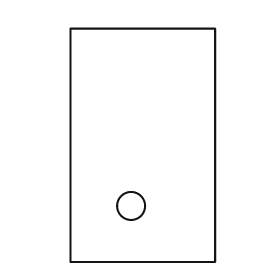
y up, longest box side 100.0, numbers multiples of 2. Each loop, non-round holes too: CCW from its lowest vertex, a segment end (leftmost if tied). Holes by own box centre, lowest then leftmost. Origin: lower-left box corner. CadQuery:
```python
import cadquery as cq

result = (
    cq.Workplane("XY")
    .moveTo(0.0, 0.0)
    .lineTo(62.0, 0.0)
    .lineTo(62.0, 100.0)
    .lineTo(0.0, 100.0)
    .close()
    .moveTo(26.0, 24.0)
    .circle(6.0)
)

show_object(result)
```